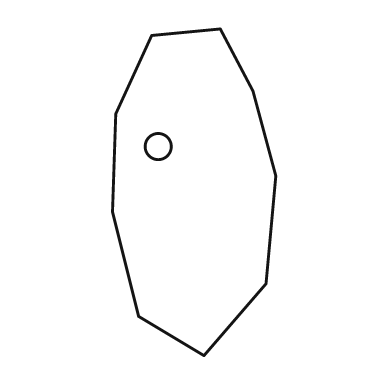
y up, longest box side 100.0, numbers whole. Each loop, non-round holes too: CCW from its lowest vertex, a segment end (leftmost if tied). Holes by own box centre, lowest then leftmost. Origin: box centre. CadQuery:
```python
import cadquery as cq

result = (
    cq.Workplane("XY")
    .moveTo(3.0, -50.0)
    .lineTo(22.0, -28.0)
    .lineTo(25.0, 5.0)
    .lineTo(18.0, 31.0)
    .lineTo(8.0, 50.0)
    .lineTo(-13.0, 48.0)
    .lineTo(-24.0, 24.0)
    .lineTo(-25.0, -6.0)
    .lineTo(-17.0, -38.0)
    .close()
    .moveTo(-11.0, 14.0)
    .circle(4.0)
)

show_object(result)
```